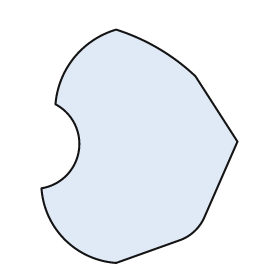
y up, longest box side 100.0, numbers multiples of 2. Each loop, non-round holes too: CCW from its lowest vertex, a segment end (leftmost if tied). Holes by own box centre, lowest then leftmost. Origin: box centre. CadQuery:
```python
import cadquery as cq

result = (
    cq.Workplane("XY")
    .moveTo(-10.0, -50.0)
    .lineTo(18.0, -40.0)
    .threePointArc((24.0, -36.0), (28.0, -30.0))
    .lineTo(42.0, 2.0)
    .lineTo(24.0, 30.0)
    .threePointArc((8.0, 42.0), (-10.0, 50.0))
    .threePointArc((-28.0, 38.0), (-36.0, 18.0))
    .threePointArc((-26.0, -2.0), (-42.0, -18.0))
    .threePointArc((-32.0, -40.0), (-10.0, -50.0))
    .close()
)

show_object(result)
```